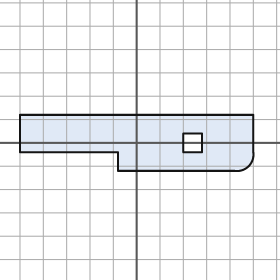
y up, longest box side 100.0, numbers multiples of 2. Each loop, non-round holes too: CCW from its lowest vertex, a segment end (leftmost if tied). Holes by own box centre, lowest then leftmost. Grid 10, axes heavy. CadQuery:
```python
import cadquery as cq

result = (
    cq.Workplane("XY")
    .moveTo(-8.0, -12.0)
    .lineTo(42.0, -12.0)
    .threePointArc((48.0, -10.0), (50.0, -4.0))
    .lineTo(50.0, 12.0)
    .lineTo(-50.0, 12.0)
    .lineTo(-50.0, -4.0)
    .lineTo(-8.0, -4.0)
    .close()
    .moveTo(20.0, -4.0)
    .lineTo(28.0, -4.0)
    .lineTo(28.0, 4.0)
    .lineTo(20.0, 4.0)
    .close()
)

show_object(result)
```